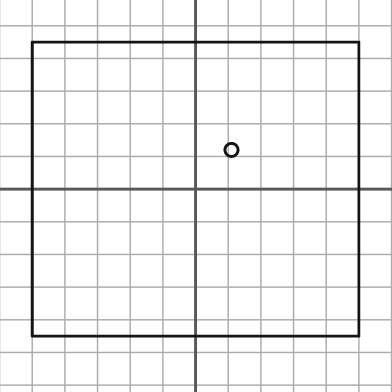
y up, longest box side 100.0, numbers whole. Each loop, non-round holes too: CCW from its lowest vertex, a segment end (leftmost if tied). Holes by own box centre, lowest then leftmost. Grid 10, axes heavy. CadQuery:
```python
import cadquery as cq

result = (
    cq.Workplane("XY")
    .moveTo(-50.0, -45.0)
    .lineTo(50.0, -45.0)
    .lineTo(50.0, 45.0)
    .lineTo(-50.0, 45.0)
    .close()
    .moveTo(11.0, 12.0)
    .circle(2.0)
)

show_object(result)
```